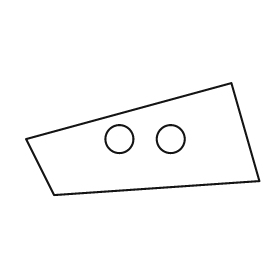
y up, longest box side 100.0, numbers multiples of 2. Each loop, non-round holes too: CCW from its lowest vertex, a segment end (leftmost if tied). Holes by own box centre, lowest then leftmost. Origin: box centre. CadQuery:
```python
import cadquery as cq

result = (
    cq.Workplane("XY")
    .moveTo(-38.0, -24.0)
    .lineTo(50.0, -18.0)
    .lineTo(38.0, 24.0)
    .lineTo(-50.0, 0.0)
    .close()
    .moveTo(-10.0, 0.0)
    .circle(6.0)
    .moveTo(12.0, 0.0)
    .circle(6.0)
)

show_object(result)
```